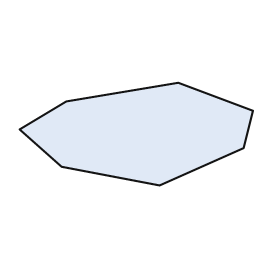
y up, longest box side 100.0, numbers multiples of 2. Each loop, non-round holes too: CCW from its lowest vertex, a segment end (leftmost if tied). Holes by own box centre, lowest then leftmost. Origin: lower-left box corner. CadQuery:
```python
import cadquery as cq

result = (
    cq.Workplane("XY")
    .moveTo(60.0, 0.0)
    .lineTo(96.0, 16.0)
    .lineTo(100.0, 32.0)
    .lineTo(68.0, 44.0)
    .lineTo(20.0, 36.0)
    .lineTo(0.0, 24.0)
    .lineTo(18.0, 8.0)
    .close()
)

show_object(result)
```